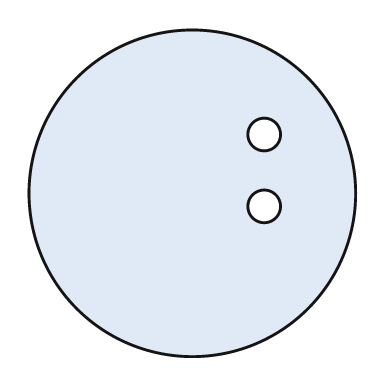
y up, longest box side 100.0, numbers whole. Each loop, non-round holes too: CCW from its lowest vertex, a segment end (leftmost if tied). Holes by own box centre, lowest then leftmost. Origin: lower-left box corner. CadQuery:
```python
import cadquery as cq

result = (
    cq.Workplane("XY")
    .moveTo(50.0, 50.0)
    .circle(50.0)
    .moveTo(72.0, 46.0)
    .circle(5.0)
    .moveTo(72.0, 68.0)
    .circle(5.0)
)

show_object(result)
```